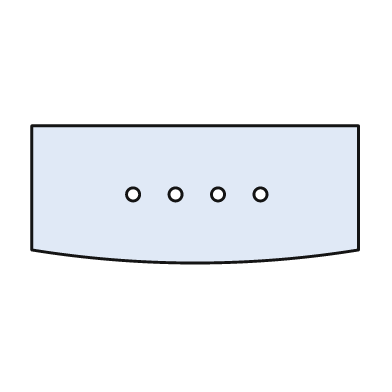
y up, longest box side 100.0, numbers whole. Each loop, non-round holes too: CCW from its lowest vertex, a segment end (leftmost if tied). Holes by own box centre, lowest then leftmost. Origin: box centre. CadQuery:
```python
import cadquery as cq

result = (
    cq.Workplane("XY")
    .moveTo(-50.0, -17.0)
    .threePointArc((0.0, -21.0), (50.0, -17.0))
    .lineTo(50.0, 21.0)
    .lineTo(-50.0, 21.0)
    .close()
    .moveTo(-19.0, 0.0)
    .circle(2.0)
    .moveTo(-6.0, 0.0)
    .circle(2.0)
    .moveTo(7.0, 0.0)
    .circle(2.0)
    .moveTo(20.0, 0.0)
    .circle(2.0)
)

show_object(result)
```